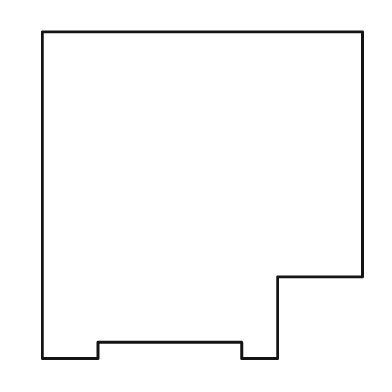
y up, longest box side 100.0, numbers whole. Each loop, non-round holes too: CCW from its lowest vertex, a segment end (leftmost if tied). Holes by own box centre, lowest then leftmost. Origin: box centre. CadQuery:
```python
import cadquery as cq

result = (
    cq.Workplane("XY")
    .moveTo(-49.0, -50.0)
    .lineTo(-32.0, -50.0)
    .lineTo(-32.0, -45.0)
    .lineTo(12.0, -45.0)
    .lineTo(12.0, -50.0)
    .lineTo(23.0, -50.0)
    .lineTo(23.0, -25.0)
    .lineTo(49.0, -25.0)
    .lineTo(49.0, 50.0)
    .lineTo(-49.0, 50.0)
    .close()
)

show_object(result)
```